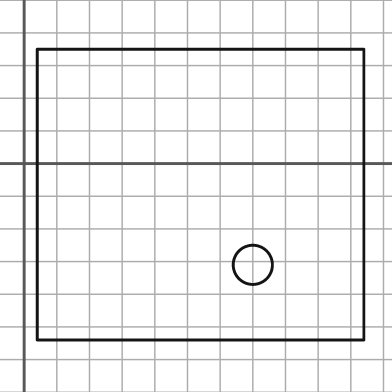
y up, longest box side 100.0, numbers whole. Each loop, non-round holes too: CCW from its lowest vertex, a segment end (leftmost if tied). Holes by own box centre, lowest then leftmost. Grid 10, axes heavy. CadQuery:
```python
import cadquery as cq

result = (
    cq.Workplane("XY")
    .moveTo(4.0, -54.0)
    .lineTo(104.0, -54.0)
    .lineTo(104.0, 35.0)
    .lineTo(4.0, 35.0)
    .close()
    .moveTo(70.0, -31.0)
    .circle(6.0)
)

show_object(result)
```